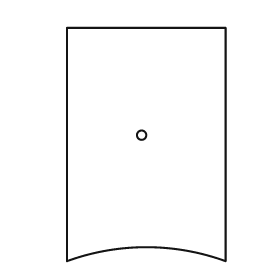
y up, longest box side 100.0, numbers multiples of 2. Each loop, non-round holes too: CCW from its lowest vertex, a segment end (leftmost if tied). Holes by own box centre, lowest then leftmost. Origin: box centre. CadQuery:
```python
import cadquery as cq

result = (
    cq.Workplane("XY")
    .moveTo(-34.0, -50.0)
    .threePointArc((0.0, -44.0), (34.0, -50.0))
    .lineTo(34.0, 50.0)
    .lineTo(-34.0, 50.0)
    .close()
    .moveTo(-2.0, 4.0)
    .circle(2.0)
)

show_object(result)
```